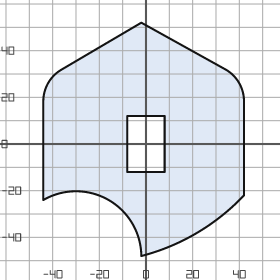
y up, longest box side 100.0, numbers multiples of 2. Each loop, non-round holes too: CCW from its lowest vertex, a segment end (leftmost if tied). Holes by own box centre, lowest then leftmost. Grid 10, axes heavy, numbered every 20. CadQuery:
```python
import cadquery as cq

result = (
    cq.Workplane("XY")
    .moveTo(-2.0, -48.0)
    .threePointArc((22.0, -38.0), (42.0, -22.0))
    .lineTo(42.0, 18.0)
    .threePointArc((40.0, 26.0), (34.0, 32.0))
    .lineTo(-2.0, 52.0)
    .lineTo(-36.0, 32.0)
    .threePointArc((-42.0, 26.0), (-44.0, 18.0))
    .lineTo(-44.0, -24.0)
    .threePointArc((-16.0, -24.0), (-2.0, -48.0))
    .close()
    .moveTo(-8.0, -12.0)
    .lineTo(8.0, -12.0)
    .lineTo(8.0, 12.0)
    .lineTo(-8.0, 12.0)
    .close()
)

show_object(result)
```